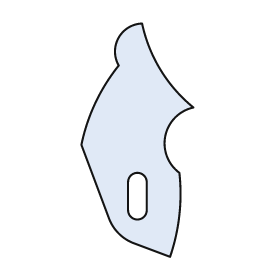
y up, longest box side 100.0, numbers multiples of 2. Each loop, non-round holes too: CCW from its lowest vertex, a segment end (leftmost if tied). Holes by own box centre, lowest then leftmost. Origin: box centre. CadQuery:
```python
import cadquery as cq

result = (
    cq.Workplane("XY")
    .moveTo(14.0, -50.0)
    .threePointArc((18.0, -32.0), (18.0, -14.0))
    .threePointArc((12.0, 2.0), (24.0, 14.0))
    .threePointArc((10.0, 30.0), (2.0, 50.0))
    .threePointArc((-8.0, 44.0), (-8.0, 32.0))
    .threePointArc((-18.0, 16.0), (-24.0, -2.0))
    .lineTo(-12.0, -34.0)
    .threePointArc((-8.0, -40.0), (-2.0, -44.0))
    .close()
    .moveTo(-4.0, -30.0)
    .threePointArc((0.0, -34.0), (4.0, -30.0))
    .lineTo(4.0, -18.0)
    .threePointArc((0.0, -14.0), (-4.0, -18.0))
    .close()
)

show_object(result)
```